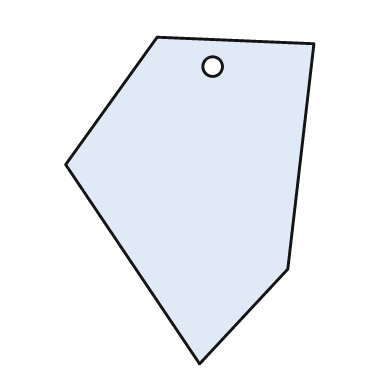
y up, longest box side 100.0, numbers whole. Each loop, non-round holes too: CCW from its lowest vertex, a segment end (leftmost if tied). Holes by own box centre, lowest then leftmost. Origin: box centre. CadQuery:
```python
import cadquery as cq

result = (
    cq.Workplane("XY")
    .moveTo(3.0, -50.0)
    .lineTo(30.0, -21.0)
    .lineTo(38.0, 48.0)
    .lineTo(-10.0, 50.0)
    .lineTo(-38.0, 11.0)
    .close()
    .moveTo(7.0, 41.0)
    .circle(3.0)
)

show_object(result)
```